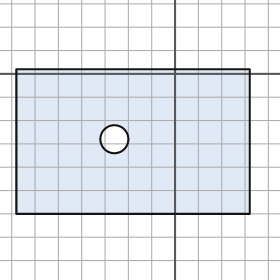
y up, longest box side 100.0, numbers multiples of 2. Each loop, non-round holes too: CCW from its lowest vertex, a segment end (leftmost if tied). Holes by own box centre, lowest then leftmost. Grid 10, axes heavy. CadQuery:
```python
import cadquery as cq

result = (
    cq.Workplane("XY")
    .moveTo(-68.0, -60.0)
    .lineTo(32.0, -60.0)
    .lineTo(32.0, 2.0)
    .lineTo(-68.0, 2.0)
    .close()
    .moveTo(-26.0, -28.0)
    .circle(6.0)
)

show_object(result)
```